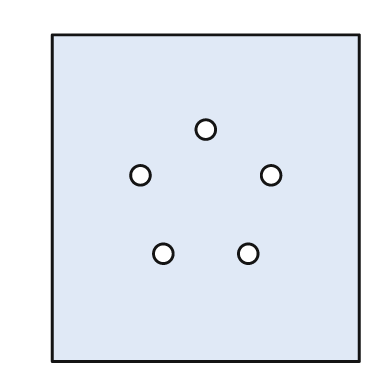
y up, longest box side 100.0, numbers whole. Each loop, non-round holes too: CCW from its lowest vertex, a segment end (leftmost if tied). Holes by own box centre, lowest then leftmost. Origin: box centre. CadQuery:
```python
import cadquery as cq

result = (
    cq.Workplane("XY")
    .moveTo(-47.0, -50.0)
    .lineTo(47.0, -50.0)
    .lineTo(47.0, 50.0)
    .lineTo(-47.0, 50.0)
    .close()
    .moveTo(-13.0, -17.0)
    .circle(3.0)
    .moveTo(13.0, -17.0)
    .circle(3.0)
    .moveTo(-20.0, 7.0)
    .circle(3.0)
    .moveTo(20.0, 7.0)
    .circle(3.0)
    .moveTo(0.0, 21.0)
    .circle(3.0)
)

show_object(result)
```